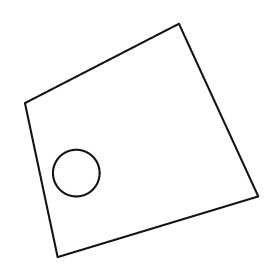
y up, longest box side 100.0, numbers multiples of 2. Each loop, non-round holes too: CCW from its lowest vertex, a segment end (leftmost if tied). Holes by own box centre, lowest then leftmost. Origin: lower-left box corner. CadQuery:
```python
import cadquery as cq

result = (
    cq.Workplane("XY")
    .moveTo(14.0, 0.0)
    .lineTo(100.0, 26.0)
    .lineTo(66.0, 100.0)
    .lineTo(0.0, 66.0)
    .close()
    .moveTo(22.0, 36.0)
    .circle(10.0)
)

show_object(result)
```